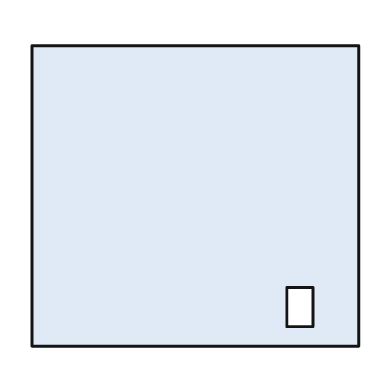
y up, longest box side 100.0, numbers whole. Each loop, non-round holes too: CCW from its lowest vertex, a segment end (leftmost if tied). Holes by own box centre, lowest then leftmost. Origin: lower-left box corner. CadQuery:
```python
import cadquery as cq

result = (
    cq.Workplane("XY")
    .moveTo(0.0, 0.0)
    .lineTo(100.0, 0.0)
    .lineTo(100.0, 92.0)
    .lineTo(0.0, 92.0)
    .close()
    .moveTo(78.0, 6.0)
    .lineTo(86.0, 6.0)
    .lineTo(86.0, 18.0)
    .lineTo(78.0, 18.0)
    .close()
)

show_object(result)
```